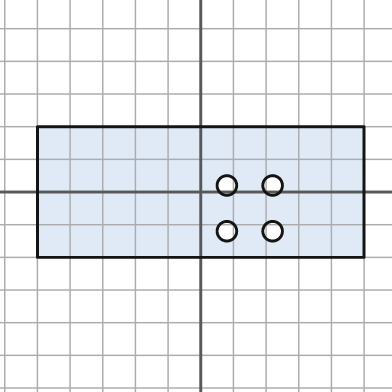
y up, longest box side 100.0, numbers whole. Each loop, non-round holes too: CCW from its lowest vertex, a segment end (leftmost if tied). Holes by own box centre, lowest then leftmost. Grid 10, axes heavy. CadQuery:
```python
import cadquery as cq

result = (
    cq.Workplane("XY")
    .moveTo(-50.0, -20.0)
    .lineTo(50.0, -20.0)
    .lineTo(50.0, 20.0)
    .lineTo(-50.0, 20.0)
    .close()
    .moveTo(8.0, -12.0)
    .circle(3.0)
    .moveTo(22.0, -12.0)
    .circle(3.0)
    .moveTo(8.0, 2.0)
    .circle(3.0)
    .moveTo(22.0, 2.0)
    .circle(3.0)
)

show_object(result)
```